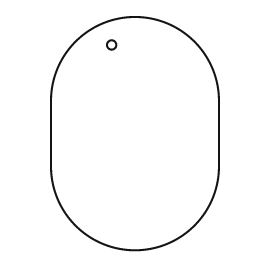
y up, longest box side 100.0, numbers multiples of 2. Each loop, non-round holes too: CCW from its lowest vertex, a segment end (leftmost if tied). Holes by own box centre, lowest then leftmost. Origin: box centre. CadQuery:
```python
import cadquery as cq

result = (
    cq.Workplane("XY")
    .moveTo(-36.0, -14.0)
    .threePointArc((0.0, -50.0), (36.0, -14.0))
    .lineTo(36.0, 14.0)
    .threePointArc((0.0, 50.0), (-36.0, 14.0))
    .close()
    .moveTo(-10.0, 38.0)
    .circle(2.0)
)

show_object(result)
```